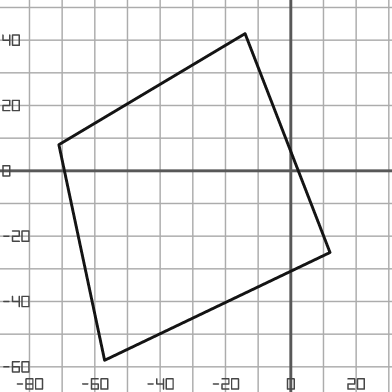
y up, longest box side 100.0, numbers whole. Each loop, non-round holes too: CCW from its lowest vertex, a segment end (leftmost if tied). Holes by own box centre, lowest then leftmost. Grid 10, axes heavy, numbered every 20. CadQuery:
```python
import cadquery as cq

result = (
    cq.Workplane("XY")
    .moveTo(-57.0, -58.0)
    .lineTo(12.0, -25.0)
    .lineTo(-14.0, 42.0)
    .lineTo(-71.0, 8.0)
    .close()
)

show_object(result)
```